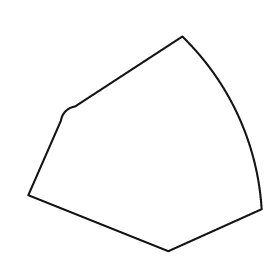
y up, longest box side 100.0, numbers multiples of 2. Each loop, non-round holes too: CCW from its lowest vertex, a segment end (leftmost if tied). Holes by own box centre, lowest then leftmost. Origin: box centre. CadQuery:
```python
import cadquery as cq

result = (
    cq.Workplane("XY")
    .moveTo(10.0, -46.0)
    .lineTo(50.0, -28.0)
    .threePointArc((40.0, 12.0), (16.0, 46.0))
    .lineTo(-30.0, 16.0)
    .threePointArc((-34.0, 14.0), (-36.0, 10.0))
    .lineTo(-50.0, -22.0)
    .close()
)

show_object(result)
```